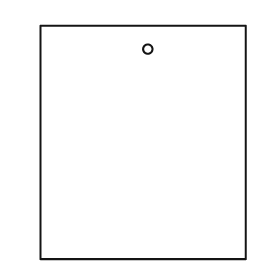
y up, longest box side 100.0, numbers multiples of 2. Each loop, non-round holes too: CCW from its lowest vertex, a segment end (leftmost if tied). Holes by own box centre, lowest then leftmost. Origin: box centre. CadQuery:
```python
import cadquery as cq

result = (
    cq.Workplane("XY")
    .moveTo(-44.0, -50.0)
    .lineTo(44.0, -50.0)
    .lineTo(44.0, 50.0)
    .lineTo(-44.0, 50.0)
    .close()
    .moveTo(2.0, 40.0)
    .circle(2.0)
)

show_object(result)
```